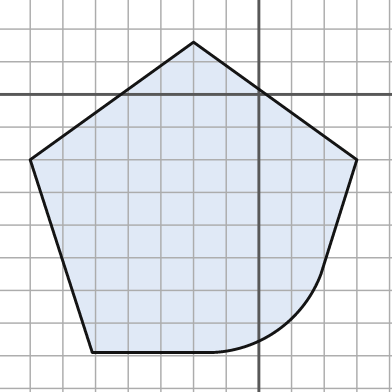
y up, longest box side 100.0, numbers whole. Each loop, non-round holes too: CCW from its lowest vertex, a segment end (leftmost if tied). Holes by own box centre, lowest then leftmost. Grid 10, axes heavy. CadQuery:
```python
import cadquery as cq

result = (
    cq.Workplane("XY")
    .moveTo(-51.0, -79.0)
    .lineTo(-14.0, -79.0)
    .threePointArc((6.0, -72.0), (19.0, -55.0))
    .lineTo(30.0, -20.0)
    .lineTo(-20.0, 16.0)
    .lineTo(-70.0, -20.0)
    .close()
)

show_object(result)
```